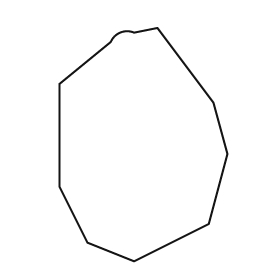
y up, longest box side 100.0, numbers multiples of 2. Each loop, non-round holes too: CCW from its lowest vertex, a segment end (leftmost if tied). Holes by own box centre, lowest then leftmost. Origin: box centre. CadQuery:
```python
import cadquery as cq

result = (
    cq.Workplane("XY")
    .moveTo(-4.0, -50.0)
    .lineTo(28.0, -34.0)
    .lineTo(36.0, -4.0)
    .lineTo(30.0, 18.0)
    .lineTo(6.0, 50.0)
    .lineTo(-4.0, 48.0)
    .threePointArc((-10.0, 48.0), (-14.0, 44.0))
    .lineTo(-36.0, 26.0)
    .lineTo(-36.0, -18.0)
    .lineTo(-24.0, -42.0)
    .close()
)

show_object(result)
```